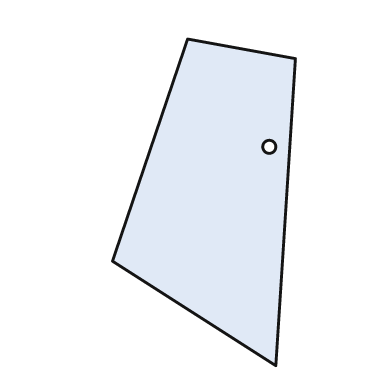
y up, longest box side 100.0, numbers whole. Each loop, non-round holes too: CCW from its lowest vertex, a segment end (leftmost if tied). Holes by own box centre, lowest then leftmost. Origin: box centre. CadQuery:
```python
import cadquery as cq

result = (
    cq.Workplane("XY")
    .moveTo(22.0, -50.0)
    .lineTo(28.0, 44.0)
    .lineTo(-5.0, 50.0)
    .lineTo(-28.0, -18.0)
    .close()
    .moveTo(20.0, 17.0)
    .circle(2.0)
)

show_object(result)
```